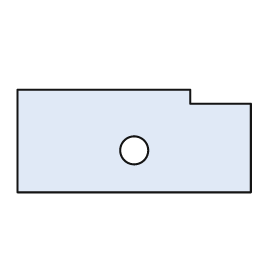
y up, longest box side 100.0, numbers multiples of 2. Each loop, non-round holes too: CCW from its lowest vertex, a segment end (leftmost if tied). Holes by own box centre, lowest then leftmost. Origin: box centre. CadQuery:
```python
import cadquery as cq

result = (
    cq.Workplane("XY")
    .moveTo(-50.0, -22.0)
    .lineTo(50.0, -22.0)
    .lineTo(50.0, 16.0)
    .lineTo(24.0, 16.0)
    .lineTo(24.0, 22.0)
    .lineTo(-50.0, 22.0)
    .close()
    .moveTo(0.0, -4.0)
    .circle(6.0)
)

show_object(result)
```